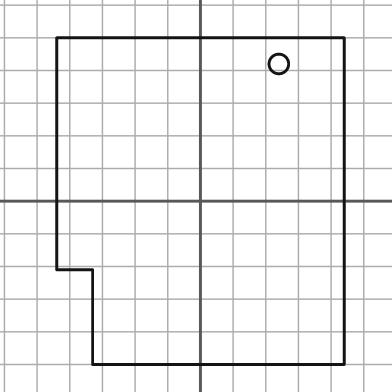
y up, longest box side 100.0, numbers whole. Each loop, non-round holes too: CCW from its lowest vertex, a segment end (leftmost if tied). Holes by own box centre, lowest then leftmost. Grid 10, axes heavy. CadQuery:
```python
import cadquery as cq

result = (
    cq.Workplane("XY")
    .moveTo(-33.0, -50.0)
    .lineTo(44.0, -50.0)
    .lineTo(44.0, 50.0)
    .lineTo(-44.0, 50.0)
    .lineTo(-44.0, -21.0)
    .lineTo(-33.0, -21.0)
    .close()
    .moveTo(24.0, 42.0)
    .circle(3.0)
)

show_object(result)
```